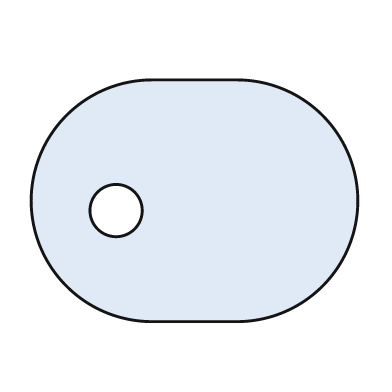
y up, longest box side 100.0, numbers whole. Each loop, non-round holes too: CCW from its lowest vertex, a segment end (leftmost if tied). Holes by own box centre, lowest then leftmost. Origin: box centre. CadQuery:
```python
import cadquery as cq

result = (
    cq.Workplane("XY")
    .moveTo(-13.0, -37.0)
    .lineTo(13.0, -37.0)
    .threePointArc((50.0, 0.0), (13.0, 37.0))
    .lineTo(-13.0, 37.0)
    .threePointArc((-50.0, 0.0), (-13.0, -37.0))
    .close()
    .moveTo(-24.0, -3.0)
    .circle(8.0)
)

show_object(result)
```